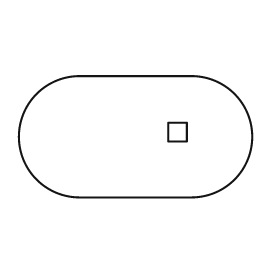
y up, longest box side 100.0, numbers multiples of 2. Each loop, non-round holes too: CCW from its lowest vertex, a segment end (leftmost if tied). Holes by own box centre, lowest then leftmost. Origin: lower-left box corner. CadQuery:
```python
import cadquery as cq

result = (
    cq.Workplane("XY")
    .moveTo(26.0, 0.0)
    .lineTo(74.0, 0.0)
    .threePointArc((100.0, 26.0), (74.0, 52.0))
    .lineTo(26.0, 52.0)
    .threePointArc((0.0, 26.0), (26.0, 0.0))
    .close()
    .moveTo(64.0, 24.0)
    .lineTo(72.0, 24.0)
    .lineTo(72.0, 32.0)
    .lineTo(64.0, 32.0)
    .close()
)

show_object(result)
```